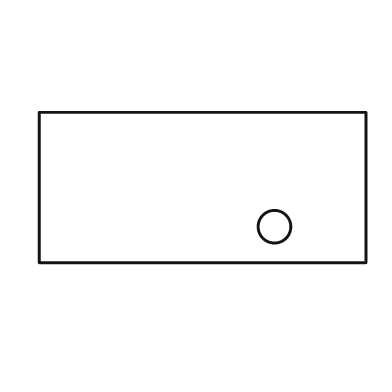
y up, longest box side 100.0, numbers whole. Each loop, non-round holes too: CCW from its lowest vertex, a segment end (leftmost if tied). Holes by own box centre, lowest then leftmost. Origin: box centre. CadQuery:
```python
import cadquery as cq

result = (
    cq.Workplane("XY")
    .moveTo(-50.0, -23.0)
    .lineTo(50.0, -23.0)
    .lineTo(50.0, 23.0)
    .lineTo(-50.0, 23.0)
    .close()
    .moveTo(22.0, -12.0)
    .circle(5.0)
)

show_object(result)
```